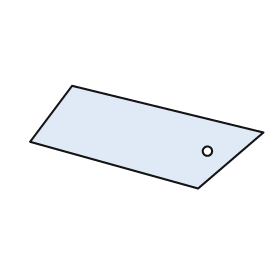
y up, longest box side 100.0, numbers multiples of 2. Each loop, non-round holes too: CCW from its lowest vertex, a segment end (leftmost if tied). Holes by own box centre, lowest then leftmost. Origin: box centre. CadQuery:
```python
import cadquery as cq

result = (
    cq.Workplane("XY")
    .moveTo(22.0, -22.0)
    .lineTo(50.0, 2.0)
    .lineTo(-32.0, 22.0)
    .lineTo(-50.0, -2.0)
    .close()
    .moveTo(26.0, -6.0)
    .circle(2.0)
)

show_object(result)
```